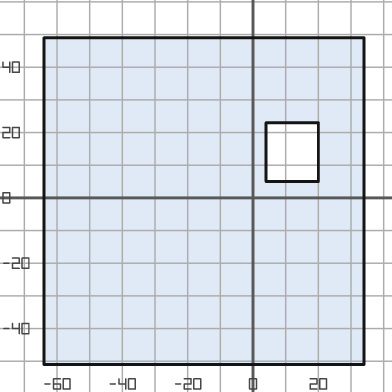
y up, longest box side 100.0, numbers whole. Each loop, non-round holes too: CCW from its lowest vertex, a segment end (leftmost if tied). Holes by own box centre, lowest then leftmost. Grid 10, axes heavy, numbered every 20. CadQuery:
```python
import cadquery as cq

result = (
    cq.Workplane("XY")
    .moveTo(-64.0, -51.0)
    .lineTo(34.0, -51.0)
    .lineTo(34.0, 49.0)
    .lineTo(-64.0, 49.0)
    .close()
    .moveTo(4.0, 5.0)
    .lineTo(20.0, 5.0)
    .lineTo(20.0, 23.0)
    .lineTo(4.0, 23.0)
    .close()
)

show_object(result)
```